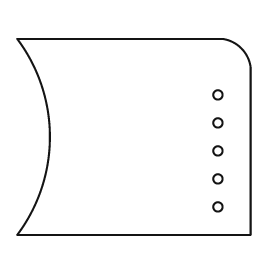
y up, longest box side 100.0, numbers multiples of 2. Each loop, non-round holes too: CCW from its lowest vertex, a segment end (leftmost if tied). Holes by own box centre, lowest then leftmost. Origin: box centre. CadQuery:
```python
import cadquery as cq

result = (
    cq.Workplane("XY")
    .moveTo(-50.0, -42.0)
    .lineTo(50.0, -42.0)
    .lineTo(50.0, 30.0)
    .threePointArc((46.0, 38.0), (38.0, 42.0))
    .lineTo(-50.0, 42.0)
    .threePointArc((-36.0, 0.0), (-50.0, -42.0))
    .close()
    .moveTo(36.0, -30.0)
    .circle(2.0)
    .moveTo(36.0, -18.0)
    .circle(2.0)
    .moveTo(36.0, -6.0)
    .circle(2.0)
    .moveTo(36.0, 6.0)
    .circle(2.0)
    .moveTo(36.0, 18.0)
    .circle(2.0)
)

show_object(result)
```